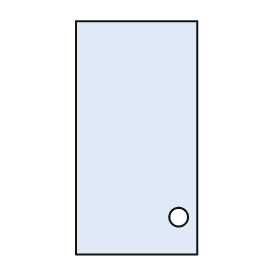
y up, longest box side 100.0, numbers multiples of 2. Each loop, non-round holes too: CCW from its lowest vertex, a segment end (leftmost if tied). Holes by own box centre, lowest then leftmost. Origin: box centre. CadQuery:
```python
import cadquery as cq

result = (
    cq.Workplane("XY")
    .moveTo(-26.0, -50.0)
    .lineTo(26.0, -50.0)
    .lineTo(26.0, 50.0)
    .lineTo(-26.0, 50.0)
    .close()
    .moveTo(18.0, -34.0)
    .circle(4.0)
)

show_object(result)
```